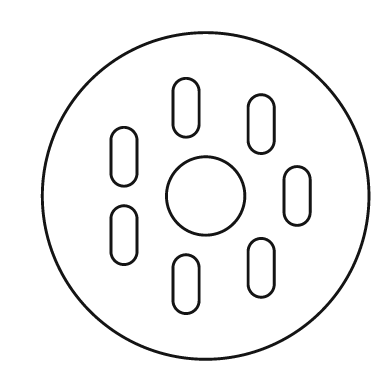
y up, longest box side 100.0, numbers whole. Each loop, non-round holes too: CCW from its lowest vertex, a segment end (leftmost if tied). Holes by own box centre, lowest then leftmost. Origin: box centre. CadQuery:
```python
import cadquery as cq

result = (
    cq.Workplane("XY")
    .moveTo(0.0, 0.0)
    .circle(50.0)
    .moveTo(-10.0, -32.0)
    .threePointArc((-6.0, -36.0), (-2.0, -32.0))
    .lineTo(-2.0, -22.0)
    .threePointArc((-6.0, -18.0), (-10.0, -22.0))
    .close()
    .moveTo(13.0, -27.0)
    .threePointArc((17.0, -31.0), (21.0, -27.0))
    .lineTo(21.0, -17.0)
    .threePointArc((17.0, -13.0), (13.0, -17.0))
    .close()
    .moveTo(-29.0, -17.0)
    .threePointArc((-25.0, -21.0), (-21.0, -17.0))
    .lineTo(-21.0, -7.0)
    .threePointArc((-25.0, -3.0), (-29.0, -7.0))
    .close()
    .moveTo(0.0, 0.0)
    .circle(12.0)
    .moveTo(24.0, -5.0)
    .threePointArc((28.0, -9.0), (32.0, -5.0))
    .lineTo(32.0, 5.0)
    .threePointArc((28.0, 9.0), (24.0, 5.0))
    .close()
    .moveTo(-29.0, 7.0)
    .threePointArc((-25.0, 3.0), (-21.0, 7.0))
    .lineTo(-21.0, 17.0)
    .threePointArc((-25.0, 21.0), (-29.0, 17.0))
    .close()
    .moveTo(13.0, 17.0)
    .threePointArc((17.0, 13.0), (21.0, 17.0))
    .lineTo(21.0, 27.0)
    .threePointArc((17.0, 31.0), (13.0, 27.0))
    .close()
    .moveTo(-10.0, 22.0)
    .threePointArc((-6.0, 18.0), (-2.0, 22.0))
    .lineTo(-2.0, 32.0)
    .threePointArc((-6.0, 36.0), (-10.0, 32.0))
    .close()
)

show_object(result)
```